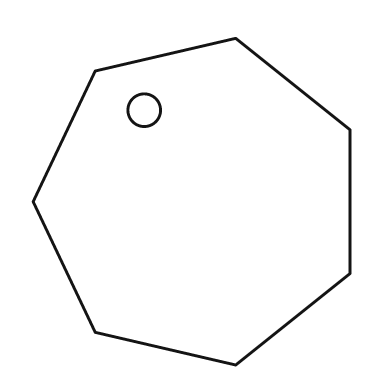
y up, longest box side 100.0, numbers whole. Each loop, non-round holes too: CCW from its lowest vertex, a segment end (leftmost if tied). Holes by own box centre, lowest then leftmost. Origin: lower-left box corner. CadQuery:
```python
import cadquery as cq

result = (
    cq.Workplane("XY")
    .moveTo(62.0, 0.0)
    .lineTo(97.0, 28.0)
    .lineTo(97.0, 72.0)
    .lineTo(62.0, 100.0)
    .lineTo(19.0, 90.0)
    .lineTo(0.0, 50.0)
    .lineTo(19.0, 10.0)
    .close()
    .moveTo(34.0, 78.0)
    .circle(5.0)
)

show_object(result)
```